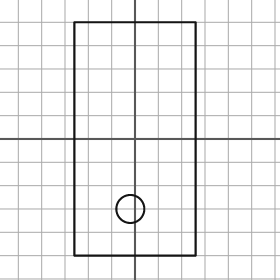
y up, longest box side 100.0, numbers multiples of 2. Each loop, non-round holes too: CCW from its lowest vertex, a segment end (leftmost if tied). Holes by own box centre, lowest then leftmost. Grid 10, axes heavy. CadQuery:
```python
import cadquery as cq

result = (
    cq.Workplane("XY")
    .moveTo(-26.0, -50.0)
    .lineTo(26.0, -50.0)
    .lineTo(26.0, 50.0)
    .lineTo(-26.0, 50.0)
    .close()
    .moveTo(-2.0, -30.0)
    .circle(6.0)
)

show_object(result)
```